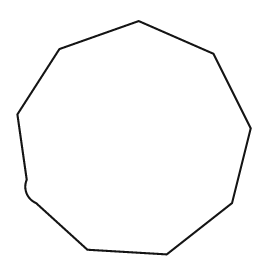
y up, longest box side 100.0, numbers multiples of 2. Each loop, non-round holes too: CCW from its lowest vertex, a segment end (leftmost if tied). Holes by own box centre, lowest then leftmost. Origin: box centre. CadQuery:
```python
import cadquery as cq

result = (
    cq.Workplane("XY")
    .moveTo(14.0, -50.0)
    .lineTo(42.0, -28.0)
    .lineTo(50.0, 4.0)
    .lineTo(34.0, 36.0)
    .lineTo(2.0, 50.0)
    .lineTo(-32.0, 38.0)
    .lineTo(-50.0, 10.0)
    .lineTo(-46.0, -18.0)
    .threePointArc((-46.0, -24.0), (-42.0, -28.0))
    .lineTo(-20.0, -48.0)
    .close()
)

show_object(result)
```